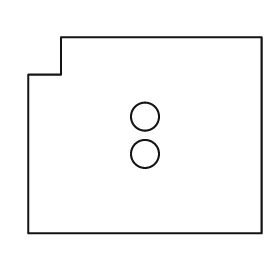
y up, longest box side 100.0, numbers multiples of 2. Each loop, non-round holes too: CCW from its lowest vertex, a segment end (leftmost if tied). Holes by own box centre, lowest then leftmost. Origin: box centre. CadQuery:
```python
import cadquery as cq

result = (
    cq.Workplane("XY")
    .moveTo(-50.0, -42.0)
    .lineTo(50.0, -42.0)
    .lineTo(50.0, 42.0)
    .lineTo(-36.0, 42.0)
    .lineTo(-36.0, 26.0)
    .lineTo(-50.0, 26.0)
    .close()
    .moveTo(0.0, -8.0)
    .circle(6.0)
    .moveTo(0.0, 8.0)
    .circle(6.0)
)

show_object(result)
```